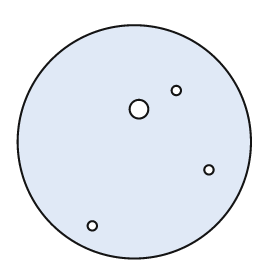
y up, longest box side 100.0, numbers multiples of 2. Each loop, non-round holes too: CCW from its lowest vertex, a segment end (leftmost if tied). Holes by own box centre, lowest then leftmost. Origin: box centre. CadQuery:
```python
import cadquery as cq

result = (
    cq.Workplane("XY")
    .moveTo(0.0, 0.0)
    .circle(50.0)
    .moveTo(-18.0, -36.0)
    .circle(2.0)
    .moveTo(32.0, -12.0)
    .circle(2.0)
    .moveTo(2.0, 14.0)
    .circle(4.0)
    .moveTo(18.0, 22.0)
    .circle(2.0)
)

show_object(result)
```